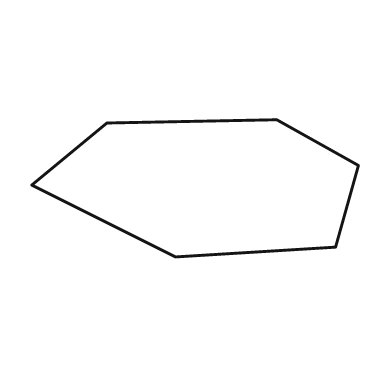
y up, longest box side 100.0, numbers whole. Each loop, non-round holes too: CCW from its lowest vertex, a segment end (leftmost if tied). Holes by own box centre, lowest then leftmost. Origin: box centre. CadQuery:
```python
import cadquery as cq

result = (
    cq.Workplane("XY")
    .moveTo(-6.0, -21.0)
    .lineTo(43.0, -18.0)
    .lineTo(50.0, 7.0)
    .lineTo(25.0, 21.0)
    .lineTo(-27.0, 20.0)
    .lineTo(-50.0, 1.0)
    .close()
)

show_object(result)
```